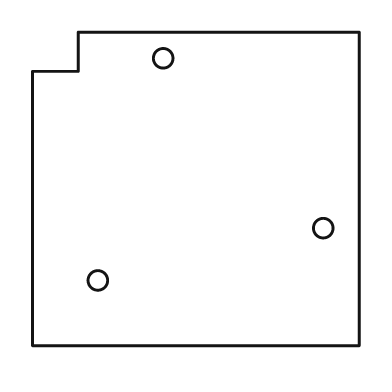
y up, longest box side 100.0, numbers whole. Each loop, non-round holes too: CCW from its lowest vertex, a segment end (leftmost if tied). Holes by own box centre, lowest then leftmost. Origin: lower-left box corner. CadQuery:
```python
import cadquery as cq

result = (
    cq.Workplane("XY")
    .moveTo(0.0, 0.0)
    .lineTo(100.0, 0.0)
    .lineTo(100.0, 96.0)
    .lineTo(14.0, 96.0)
    .lineTo(14.0, 84.0)
    .lineTo(0.0, 84.0)
    .close()
    .moveTo(20.0, 20.0)
    .circle(3.0)
    .moveTo(89.0, 36.0)
    .circle(3.0)
    .moveTo(40.0, 88.0)
    .circle(3.0)
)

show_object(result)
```